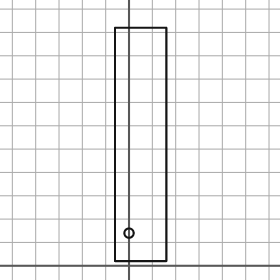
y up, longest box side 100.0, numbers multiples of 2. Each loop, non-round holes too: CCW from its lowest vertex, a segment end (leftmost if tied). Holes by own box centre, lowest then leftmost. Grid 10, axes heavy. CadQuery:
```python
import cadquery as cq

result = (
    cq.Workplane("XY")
    .moveTo(-6.0, 2.0)
    .lineTo(16.0, 2.0)
    .lineTo(16.0, 102.0)
    .lineTo(-6.0, 102.0)
    .close()
    .moveTo(0.0, 14.0)
    .circle(2.0)
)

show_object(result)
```